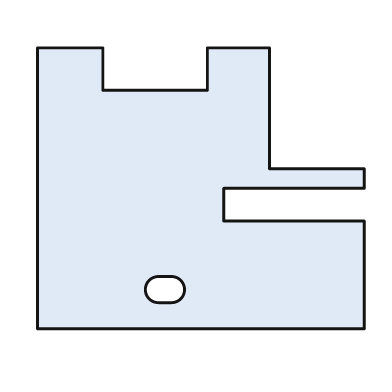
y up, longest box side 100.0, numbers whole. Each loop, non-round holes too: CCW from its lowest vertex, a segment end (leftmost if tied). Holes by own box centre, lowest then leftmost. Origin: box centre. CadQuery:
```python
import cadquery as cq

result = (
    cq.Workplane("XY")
    .moveTo(-50.0, -43.0)
    .lineTo(50.0, -43.0)
    .lineTo(50.0, -10.0)
    .lineTo(7.0, -10.0)
    .lineTo(7.0, 0.0)
    .lineTo(50.0, 0.0)
    .lineTo(50.0, 6.0)
    .lineTo(21.0, 6.0)
    .lineTo(21.0, 43.0)
    .lineTo(2.0, 43.0)
    .lineTo(2.0, 30.0)
    .lineTo(-30.0, 30.0)
    .lineTo(-30.0, 43.0)
    .lineTo(-50.0, 43.0)
    .close()
    .moveTo(-13.0, -35.0)
    .lineTo(-9.0, -35.0)
    .threePointArc((-5.0, -31.0), (-9.0, -27.0))
    .lineTo(-13.0, -27.0)
    .threePointArc((-17.0, -31.0), (-13.0, -35.0))
    .close()
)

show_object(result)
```